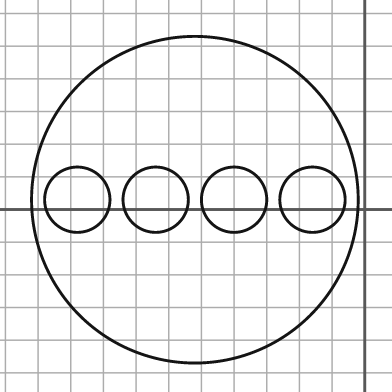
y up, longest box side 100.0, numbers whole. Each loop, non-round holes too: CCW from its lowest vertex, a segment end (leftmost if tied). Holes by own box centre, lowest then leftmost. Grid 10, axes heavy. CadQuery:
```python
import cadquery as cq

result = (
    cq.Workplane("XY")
    .moveTo(-52.0, 3.0)
    .circle(50.0)
    .moveTo(-88.0, 3.0)
    .circle(10.0)
    .moveTo(-64.0, 3.0)
    .circle(10.0)
    .moveTo(-40.0, 3.0)
    .circle(10.0)
    .moveTo(-16.0, 3.0)
    .circle(10.0)
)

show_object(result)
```